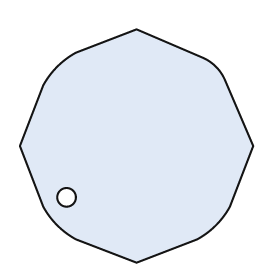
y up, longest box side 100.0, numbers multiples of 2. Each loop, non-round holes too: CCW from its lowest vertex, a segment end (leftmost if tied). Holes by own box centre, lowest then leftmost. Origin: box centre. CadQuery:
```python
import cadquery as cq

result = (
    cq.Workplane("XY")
    .moveTo(0.0, -50.0)
    .lineTo(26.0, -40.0)
    .threePointArc((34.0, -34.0), (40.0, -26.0))
    .lineTo(50.0, 0.0)
    .lineTo(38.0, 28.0)
    .threePointArc((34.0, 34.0), (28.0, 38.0))
    .lineTo(0.0, 50.0)
    .lineTo(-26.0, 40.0)
    .threePointArc((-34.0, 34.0), (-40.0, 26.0))
    .lineTo(-50.0, 0.0)
    .lineTo(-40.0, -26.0)
    .threePointArc((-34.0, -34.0), (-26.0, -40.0))
    .close()
    .moveTo(-30.0, -22.0)
    .circle(4.0)
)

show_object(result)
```